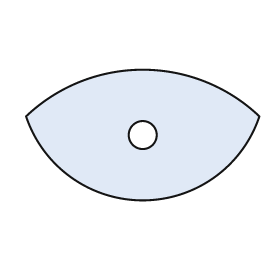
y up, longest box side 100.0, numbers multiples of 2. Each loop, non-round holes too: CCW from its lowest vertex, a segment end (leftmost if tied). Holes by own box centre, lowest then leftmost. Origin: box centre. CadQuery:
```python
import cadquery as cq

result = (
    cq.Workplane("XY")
    .moveTo(-50.0, 8.0)
    .threePointArc((0.0, -28.0), (50.0, 8.0))
    .threePointArc((0.0, 28.0), (-50.0, 8.0))
    .close()
    .moveTo(0.0, 0.0)
    .circle(6.0)
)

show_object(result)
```